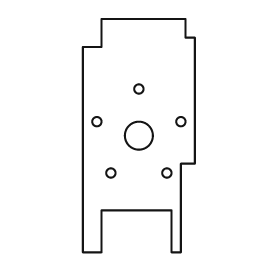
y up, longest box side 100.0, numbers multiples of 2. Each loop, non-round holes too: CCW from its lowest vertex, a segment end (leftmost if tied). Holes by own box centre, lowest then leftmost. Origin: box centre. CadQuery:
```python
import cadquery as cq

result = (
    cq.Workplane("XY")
    .moveTo(-24.0, -50.0)
    .lineTo(-16.0, -50.0)
    .lineTo(-16.0, -32.0)
    .lineTo(14.0, -32.0)
    .lineTo(14.0, -50.0)
    .lineTo(18.0, -50.0)
    .lineTo(18.0, -12.0)
    .lineTo(24.0, -12.0)
    .lineTo(24.0, 42.0)
    .lineTo(20.0, 42.0)
    .lineTo(20.0, 50.0)
    .lineTo(-16.0, 50.0)
    .lineTo(-16.0, 38.0)
    .lineTo(-24.0, 38.0)
    .close()
    .moveTo(-12.0, -16.0)
    .circle(2.0)
    .moveTo(12.0, -16.0)
    .circle(2.0)
    .moveTo(0.0, 0.0)
    .circle(6.0)
    .moveTo(-18.0, 6.0)
    .circle(2.0)
    .moveTo(18.0, 6.0)
    .circle(2.0)
    .moveTo(0.0, 20.0)
    .circle(2.0)
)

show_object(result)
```